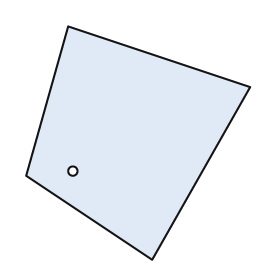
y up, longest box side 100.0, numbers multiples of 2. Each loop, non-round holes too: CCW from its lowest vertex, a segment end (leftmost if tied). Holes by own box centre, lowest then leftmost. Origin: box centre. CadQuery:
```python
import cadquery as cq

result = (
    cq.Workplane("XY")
    .moveTo(6.0, -50.0)
    .lineTo(48.0, 24.0)
    .lineTo(-30.0, 50.0)
    .lineTo(-48.0, -14.0)
    .close()
    .moveTo(-28.0, -12.0)
    .circle(2.0)
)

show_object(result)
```